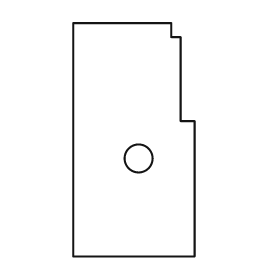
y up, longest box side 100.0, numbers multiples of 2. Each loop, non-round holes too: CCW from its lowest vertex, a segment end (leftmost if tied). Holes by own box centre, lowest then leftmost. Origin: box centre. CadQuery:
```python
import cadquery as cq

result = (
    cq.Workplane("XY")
    .moveTo(-26.0, -50.0)
    .lineTo(26.0, -50.0)
    .lineTo(26.0, 8.0)
    .lineTo(20.0, 8.0)
    .lineTo(20.0, 44.0)
    .lineTo(16.0, 44.0)
    .lineTo(16.0, 50.0)
    .lineTo(-26.0, 50.0)
    .close()
    .moveTo(2.0, -8.0)
    .circle(6.0)
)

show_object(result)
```